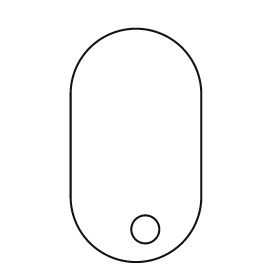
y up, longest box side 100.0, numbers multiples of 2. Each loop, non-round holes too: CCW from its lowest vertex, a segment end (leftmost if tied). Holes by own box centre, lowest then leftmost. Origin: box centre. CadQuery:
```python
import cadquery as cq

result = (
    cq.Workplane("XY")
    .moveTo(-28.0, -22.0)
    .threePointArc((0.0, -50.0), (28.0, -22.0))
    .lineTo(28.0, 22.0)
    .threePointArc((0.0, 50.0), (-28.0, 22.0))
    .close()
    .moveTo(4.0, -36.0)
    .circle(6.0)
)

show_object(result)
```